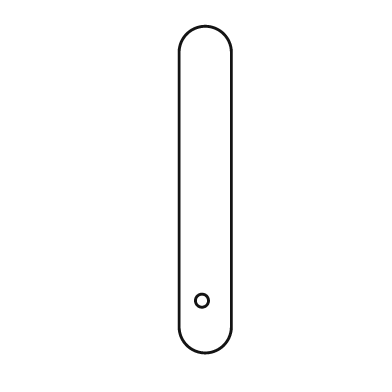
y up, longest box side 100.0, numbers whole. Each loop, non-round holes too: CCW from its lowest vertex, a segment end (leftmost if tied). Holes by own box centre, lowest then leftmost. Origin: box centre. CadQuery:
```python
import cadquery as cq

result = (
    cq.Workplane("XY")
    .moveTo(-8.0, -42.0)
    .threePointArc((0.0, -50.0), (8.0, -42.0))
    .lineTo(8.0, 42.0)
    .threePointArc((0.0, 50.0), (-8.0, 42.0))
    .close()
    .moveTo(-1.0, -34.0)
    .circle(2.0)
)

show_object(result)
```